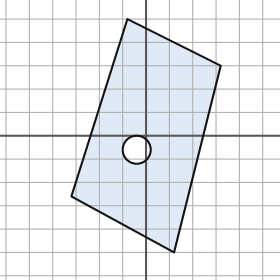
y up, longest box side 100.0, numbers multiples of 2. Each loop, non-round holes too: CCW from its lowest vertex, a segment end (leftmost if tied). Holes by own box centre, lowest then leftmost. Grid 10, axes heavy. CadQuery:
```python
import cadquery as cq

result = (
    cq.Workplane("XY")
    .moveTo(12.0, -50.0)
    .lineTo(32.0, 30.0)
    .lineTo(-8.0, 50.0)
    .lineTo(-32.0, -26.0)
    .close()
    .moveTo(-4.0, -6.0)
    .circle(6.0)
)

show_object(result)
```